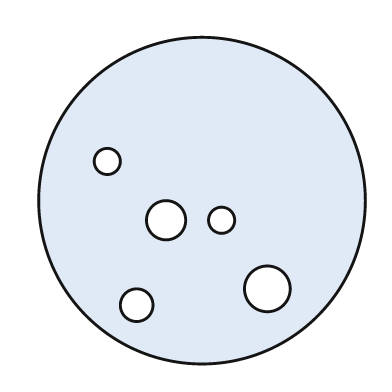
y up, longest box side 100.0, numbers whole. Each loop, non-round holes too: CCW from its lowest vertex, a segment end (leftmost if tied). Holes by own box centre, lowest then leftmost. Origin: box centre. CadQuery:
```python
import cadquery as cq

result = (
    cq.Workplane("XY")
    .moveTo(0.0, 0.0)
    .circle(50.0)
    .moveTo(-20.0, -32.0)
    .circle(5.0)
    .moveTo(20.0, -27.0)
    .circle(7.0)
    .moveTo(-11.0, -6.0)
    .circle(6.0)
    .moveTo(6.0, -6.0)
    .circle(4.0)
    .moveTo(-29.0, 12.0)
    .circle(4.0)
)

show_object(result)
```